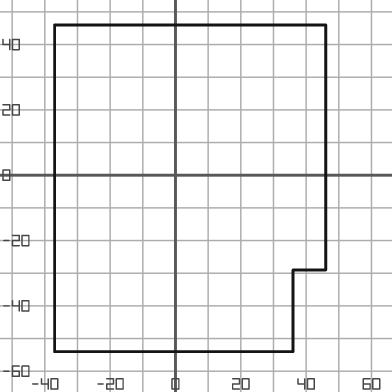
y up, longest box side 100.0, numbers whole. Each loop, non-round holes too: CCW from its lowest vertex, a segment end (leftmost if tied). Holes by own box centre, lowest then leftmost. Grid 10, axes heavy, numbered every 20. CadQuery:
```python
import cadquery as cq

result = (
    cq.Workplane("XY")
    .moveTo(-37.0, -54.0)
    .lineTo(36.0, -54.0)
    .lineTo(36.0, -29.0)
    .lineTo(46.0, -29.0)
    .lineTo(46.0, 46.0)
    .lineTo(-37.0, 46.0)
    .close()
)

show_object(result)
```